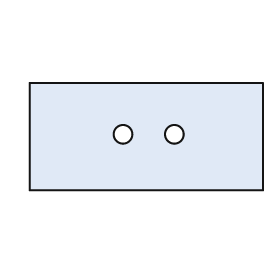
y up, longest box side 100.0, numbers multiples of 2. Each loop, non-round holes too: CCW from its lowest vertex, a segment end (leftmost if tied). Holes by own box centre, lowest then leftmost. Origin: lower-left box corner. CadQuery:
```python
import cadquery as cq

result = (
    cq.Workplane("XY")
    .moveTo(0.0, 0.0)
    .lineTo(100.0, 0.0)
    .lineTo(100.0, 46.0)
    .lineTo(0.0, 46.0)
    .close()
    .moveTo(40.0, 24.0)
    .circle(4.0)
    .moveTo(62.0, 24.0)
    .circle(4.0)
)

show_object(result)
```